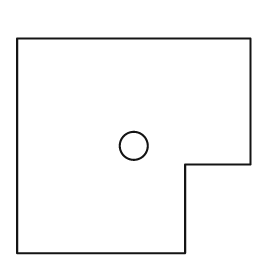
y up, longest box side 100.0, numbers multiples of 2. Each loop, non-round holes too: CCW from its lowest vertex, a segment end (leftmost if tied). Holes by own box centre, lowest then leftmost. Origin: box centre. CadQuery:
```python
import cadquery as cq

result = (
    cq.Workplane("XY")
    .moveTo(-50.0, -46.0)
    .lineTo(22.0, -46.0)
    .lineTo(22.0, -8.0)
    .lineTo(50.0, -8.0)
    .lineTo(50.0, 46.0)
    .lineTo(-50.0, 46.0)
    .close()
    .moveTo(0.0, 0.0)
    .circle(6.0)
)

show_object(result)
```